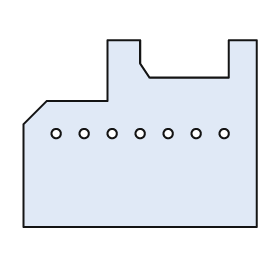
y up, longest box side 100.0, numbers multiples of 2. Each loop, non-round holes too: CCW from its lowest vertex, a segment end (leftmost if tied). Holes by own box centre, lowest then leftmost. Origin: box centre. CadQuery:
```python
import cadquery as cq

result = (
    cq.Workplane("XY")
    .moveTo(-50.0, -40.0)
    .lineTo(50.0, -40.0)
    .lineTo(50.0, 40.0)
    .lineTo(38.0, 40.0)
    .lineTo(38.0, 24.0)
    .lineTo(4.0, 24.0)
    .lineTo(0.0, 30.0)
    .lineTo(0.0, 40.0)
    .lineTo(-14.0, 40.0)
    .lineTo(-14.0, 14.0)
    .lineTo(-40.0, 14.0)
    .lineTo(-50.0, 4.0)
    .close()
    .moveTo(-36.0, 0.0)
    .circle(2.0)
    .moveTo(-24.0, 0.0)
    .circle(2.0)
    .moveTo(-12.0, 0.0)
    .circle(2.0)
    .moveTo(0.0, 0.0)
    .circle(2.0)
    .moveTo(12.0, 0.0)
    .circle(2.0)
    .moveTo(24.0, 0.0)
    .circle(2.0)
    .moveTo(36.0, 0.0)
    .circle(2.0)
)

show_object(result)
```